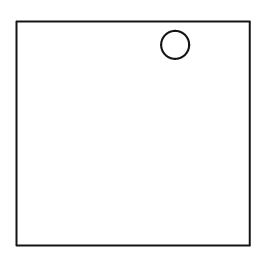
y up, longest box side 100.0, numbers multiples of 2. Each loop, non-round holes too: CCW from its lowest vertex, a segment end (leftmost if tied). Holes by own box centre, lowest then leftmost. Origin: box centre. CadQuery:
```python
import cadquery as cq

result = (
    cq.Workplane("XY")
    .moveTo(-50.0, -48.0)
    .lineTo(50.0, -48.0)
    .lineTo(50.0, 48.0)
    .lineTo(-50.0, 48.0)
    .close()
    .moveTo(18.0, 38.0)
    .circle(6.0)
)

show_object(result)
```